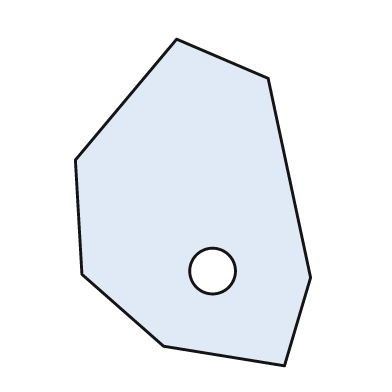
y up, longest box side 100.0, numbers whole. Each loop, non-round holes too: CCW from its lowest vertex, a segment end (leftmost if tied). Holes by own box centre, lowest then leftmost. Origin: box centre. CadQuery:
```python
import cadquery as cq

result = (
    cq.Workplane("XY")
    .moveTo(28.0, -50.0)
    .lineTo(36.0, -23.0)
    .lineTo(23.0, 38.0)
    .lineTo(-5.0, 50.0)
    .lineTo(-36.0, 13.0)
    .lineTo(-34.0, -22.0)
    .lineTo(-9.0, -44.0)
    .close()
    .moveTo(6.0, -21.0)
    .circle(7.0)
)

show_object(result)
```